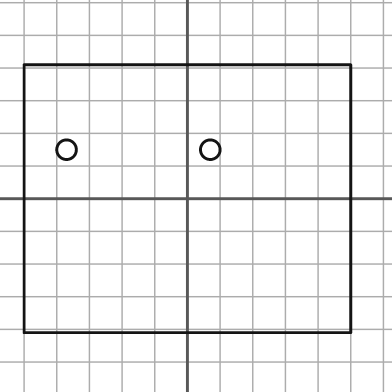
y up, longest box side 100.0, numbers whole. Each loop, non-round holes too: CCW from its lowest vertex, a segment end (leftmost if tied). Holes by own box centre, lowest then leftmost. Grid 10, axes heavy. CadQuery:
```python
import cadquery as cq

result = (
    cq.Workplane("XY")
    .moveTo(-50.0, -41.0)
    .lineTo(50.0, -41.0)
    .lineTo(50.0, 41.0)
    .lineTo(-50.0, 41.0)
    .close()
    .moveTo(-37.0, 15.0)
    .circle(3.0)
    .moveTo(7.0, 15.0)
    .circle(3.0)
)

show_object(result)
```